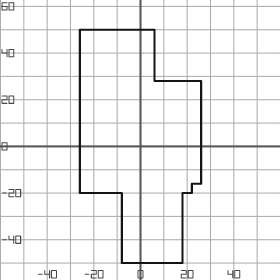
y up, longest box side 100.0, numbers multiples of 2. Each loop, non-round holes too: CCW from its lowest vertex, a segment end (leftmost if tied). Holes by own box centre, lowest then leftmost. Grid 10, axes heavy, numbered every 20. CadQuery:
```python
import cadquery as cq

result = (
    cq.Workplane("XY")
    .moveTo(-8.0, -50.0)
    .lineTo(18.0, -50.0)
    .lineTo(18.0, -20.0)
    .lineTo(22.0, -20.0)
    .lineTo(22.0, -16.0)
    .lineTo(26.0, -16.0)
    .lineTo(26.0, 28.0)
    .lineTo(6.0, 28.0)
    .lineTo(6.0, 50.0)
    .lineTo(-26.0, 50.0)
    .lineTo(-26.0, -20.0)
    .lineTo(-8.0, -20.0)
    .close()
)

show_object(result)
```